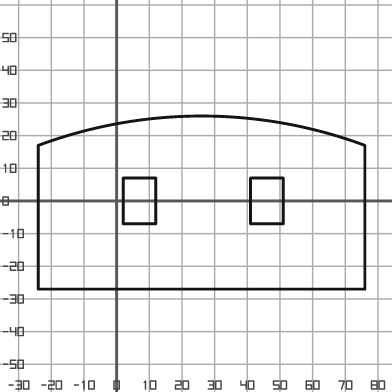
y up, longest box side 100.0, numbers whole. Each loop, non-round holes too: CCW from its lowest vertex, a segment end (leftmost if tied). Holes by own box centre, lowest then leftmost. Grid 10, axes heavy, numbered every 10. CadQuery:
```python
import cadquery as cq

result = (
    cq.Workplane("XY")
    .moveTo(-24.0, -27.0)
    .lineTo(76.0, -27.0)
    .lineTo(76.0, 17.0)
    .threePointArc((26.0, 26.0), (-24.0, 17.0))
    .close()
    .moveTo(2.0, -7.0)
    .lineTo(12.0, -7.0)
    .lineTo(12.0, 7.0)
    .lineTo(2.0, 7.0)
    .close()
    .moveTo(41.0, -7.0)
    .lineTo(51.0, -7.0)
    .lineTo(51.0, 7.0)
    .lineTo(41.0, 7.0)
    .close()
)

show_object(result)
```